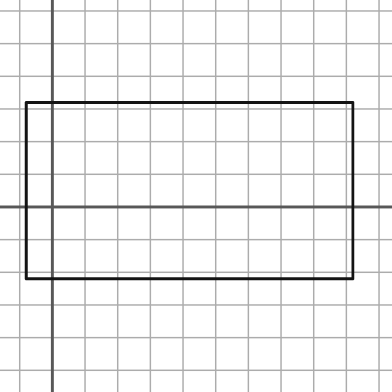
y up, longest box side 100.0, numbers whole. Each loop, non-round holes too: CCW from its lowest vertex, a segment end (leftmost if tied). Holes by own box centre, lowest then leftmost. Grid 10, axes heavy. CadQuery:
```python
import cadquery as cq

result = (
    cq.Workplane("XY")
    .moveTo(-8.0, -22.0)
    .lineTo(92.0, -22.0)
    .lineTo(92.0, 32.0)
    .lineTo(-8.0, 32.0)
    .close()
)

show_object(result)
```